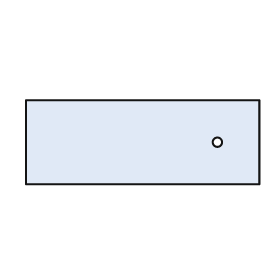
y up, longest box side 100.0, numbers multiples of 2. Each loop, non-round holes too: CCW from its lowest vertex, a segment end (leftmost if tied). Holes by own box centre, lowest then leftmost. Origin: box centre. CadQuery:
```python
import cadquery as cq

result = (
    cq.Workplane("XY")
    .moveTo(-50.0, -18.0)
    .lineTo(50.0, -18.0)
    .lineTo(50.0, 18.0)
    .lineTo(-50.0, 18.0)
    .close()
    .moveTo(32.0, 0.0)
    .circle(2.0)
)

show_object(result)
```